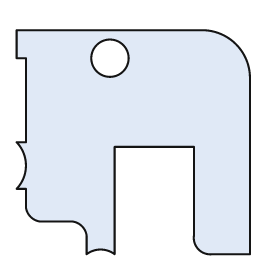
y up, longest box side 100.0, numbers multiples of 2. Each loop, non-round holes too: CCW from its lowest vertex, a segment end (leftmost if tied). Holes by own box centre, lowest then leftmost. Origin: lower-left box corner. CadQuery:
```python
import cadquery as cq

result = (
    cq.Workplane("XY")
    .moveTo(30.0, 0.0)
    .threePointArc((36.0, 2.0), (42.0, 0.0))
    .lineTo(42.0, 46.0)
    .lineTo(76.0, 46.0)
    .lineTo(76.0, 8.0)
    .threePointArc((78.0, 2.0), (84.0, 0.0))
    .lineTo(100.0, 0.0)
    .lineTo(100.0, 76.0)
    .threePointArc((94.0, 90.0), (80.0, 96.0))
    .lineTo(0.0, 96.0)
    .lineTo(0.0, 84.0)
    .lineTo(4.0, 84.0)
    .lineTo(4.0, 48.0)
    .lineTo(0.0, 48.0)
    .threePointArc((4.0, 38.0), (0.0, 28.0))
    .lineTo(4.0, 28.0)
    .lineTo(4.0, 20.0)
    .threePointArc((6.0, 16.0), (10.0, 14.0))
    .lineTo(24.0, 14.0)
    .threePointArc((28.0, 12.0), (30.0, 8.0))
    .close()
    .moveTo(40.0, 84.0)
    .circle(8.0)
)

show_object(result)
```